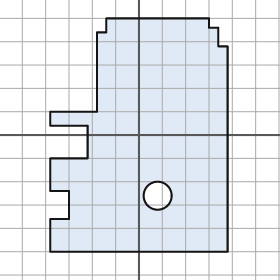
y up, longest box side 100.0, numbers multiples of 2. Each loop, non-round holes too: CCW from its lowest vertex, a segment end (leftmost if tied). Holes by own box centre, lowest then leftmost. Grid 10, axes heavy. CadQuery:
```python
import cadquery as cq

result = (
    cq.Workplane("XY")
    .moveTo(-38.0, -50.0)
    .lineTo(38.0, -50.0)
    .lineTo(38.0, 38.0)
    .lineTo(34.0, 38.0)
    .lineTo(34.0, 46.0)
    .lineTo(30.0, 46.0)
    .lineTo(30.0, 50.0)
    .lineTo(-14.0, 50.0)
    .lineTo(-14.0, 44.0)
    .lineTo(-18.0, 44.0)
    .lineTo(-18.0, 10.0)
    .lineTo(-38.0, 10.0)
    .lineTo(-38.0, 4.0)
    .lineTo(-22.0, 4.0)
    .lineTo(-22.0, -10.0)
    .lineTo(-38.0, -10.0)
    .lineTo(-38.0, -24.0)
    .lineTo(-30.0, -24.0)
    .lineTo(-30.0, -36.0)
    .lineTo(-38.0, -36.0)
    .close()
    .moveTo(8.0, -26.0)
    .circle(6.0)
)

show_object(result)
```